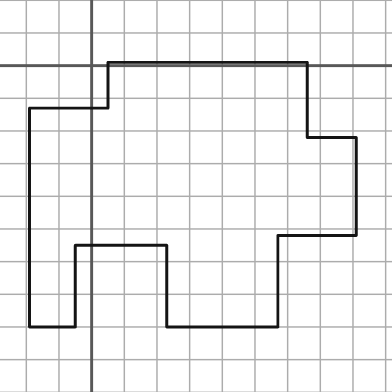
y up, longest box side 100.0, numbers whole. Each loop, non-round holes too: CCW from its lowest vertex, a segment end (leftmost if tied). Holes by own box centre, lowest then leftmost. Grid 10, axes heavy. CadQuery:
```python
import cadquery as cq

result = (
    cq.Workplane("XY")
    .moveTo(-19.0, -80.0)
    .lineTo(-5.0, -80.0)
    .lineTo(-5.0, -55.0)
    .lineTo(23.0, -55.0)
    .lineTo(23.0, -80.0)
    .lineTo(57.0, -80.0)
    .lineTo(57.0, -52.0)
    .lineTo(81.0, -52.0)
    .lineTo(81.0, -22.0)
    .lineTo(66.0, -22.0)
    .lineTo(66.0, 1.0)
    .lineTo(5.0, 1.0)
    .lineTo(5.0, -13.0)
    .lineTo(-19.0, -13.0)
    .close()
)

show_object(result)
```